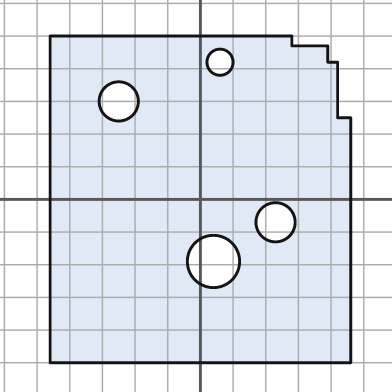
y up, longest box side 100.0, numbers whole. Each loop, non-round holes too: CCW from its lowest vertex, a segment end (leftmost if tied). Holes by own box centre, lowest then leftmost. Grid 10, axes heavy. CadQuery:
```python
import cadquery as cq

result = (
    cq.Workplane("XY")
    .moveTo(-46.0, -50.0)
    .lineTo(46.0, -50.0)
    .lineTo(46.0, 25.0)
    .lineTo(42.0, 25.0)
    .lineTo(42.0, 42.0)
    .lineTo(39.0, 42.0)
    .lineTo(39.0, 47.0)
    .lineTo(28.0, 47.0)
    .lineTo(28.0, 50.0)
    .lineTo(-46.0, 50.0)
    .close()
    .moveTo(4.0, -19.0)
    .circle(8.0)
    .moveTo(23.0, -7.0)
    .circle(6.0)
    .moveTo(-25.0, 30.0)
    .circle(6.0)
    .moveTo(6.0, 42.0)
    .circle(4.0)
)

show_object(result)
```